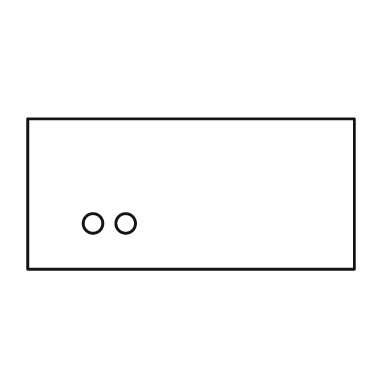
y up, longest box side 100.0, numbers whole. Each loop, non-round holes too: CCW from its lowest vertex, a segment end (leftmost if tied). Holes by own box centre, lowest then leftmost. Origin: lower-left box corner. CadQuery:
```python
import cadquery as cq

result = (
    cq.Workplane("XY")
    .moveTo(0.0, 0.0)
    .lineTo(100.0, 0.0)
    .lineTo(100.0, 46.0)
    .lineTo(0.0, 46.0)
    .close()
    .moveTo(20.0, 14.0)
    .circle(3.0)
    .moveTo(30.0, 14.0)
    .circle(3.0)
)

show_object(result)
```